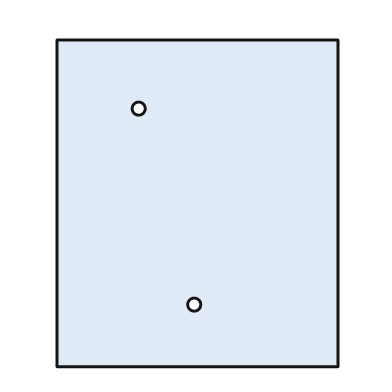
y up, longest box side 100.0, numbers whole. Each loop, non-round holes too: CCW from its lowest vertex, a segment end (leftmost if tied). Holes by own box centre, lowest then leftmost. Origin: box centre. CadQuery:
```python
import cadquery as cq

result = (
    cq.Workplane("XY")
    .moveTo(-43.0, -50.0)
    .lineTo(43.0, -50.0)
    .lineTo(43.0, 50.0)
    .lineTo(-43.0, 50.0)
    .close()
    .moveTo(-1.0, -31.0)
    .circle(2.0)
    .moveTo(-18.0, 29.0)
    .circle(2.0)
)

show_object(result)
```